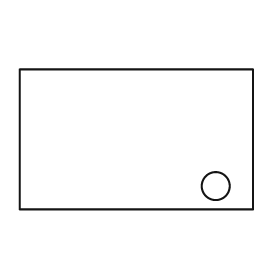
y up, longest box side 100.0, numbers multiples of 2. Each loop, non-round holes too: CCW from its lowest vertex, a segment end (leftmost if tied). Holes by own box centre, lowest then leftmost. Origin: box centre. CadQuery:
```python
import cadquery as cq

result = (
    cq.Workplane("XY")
    .moveTo(-50.0, -30.0)
    .lineTo(50.0, -30.0)
    .lineTo(50.0, 30.0)
    .lineTo(-50.0, 30.0)
    .close()
    .moveTo(34.0, -20.0)
    .circle(6.0)
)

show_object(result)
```